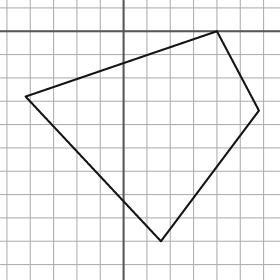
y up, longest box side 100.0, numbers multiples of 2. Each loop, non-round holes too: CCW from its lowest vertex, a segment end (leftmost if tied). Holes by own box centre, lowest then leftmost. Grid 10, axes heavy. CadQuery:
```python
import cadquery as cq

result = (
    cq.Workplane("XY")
    .moveTo(16.0, -90.0)
    .lineTo(58.0, -34.0)
    .lineTo(40.0, 0.0)
    .lineTo(-42.0, -28.0)
    .close()
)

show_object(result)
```